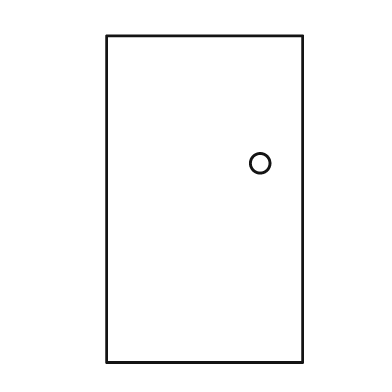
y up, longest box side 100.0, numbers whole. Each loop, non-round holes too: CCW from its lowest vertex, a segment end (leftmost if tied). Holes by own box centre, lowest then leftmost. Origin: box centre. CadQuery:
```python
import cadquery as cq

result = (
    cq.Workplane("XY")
    .moveTo(-30.0, -50.0)
    .lineTo(30.0, -50.0)
    .lineTo(30.0, 50.0)
    .lineTo(-30.0, 50.0)
    .close()
    .moveTo(17.0, 11.0)
    .circle(3.0)
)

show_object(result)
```